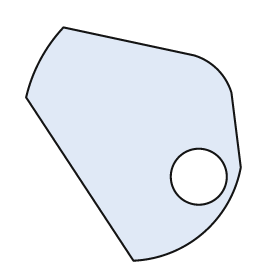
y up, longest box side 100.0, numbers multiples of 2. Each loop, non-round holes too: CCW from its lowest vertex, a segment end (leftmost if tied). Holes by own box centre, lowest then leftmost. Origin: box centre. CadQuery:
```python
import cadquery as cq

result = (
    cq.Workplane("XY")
    .moveTo(0.0, -50.0)
    .threePointArc((30.0, -38.0), (46.0, -10.0))
    .lineTo(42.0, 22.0)
    .threePointArc((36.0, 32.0), (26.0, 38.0))
    .lineTo(-30.0, 50.0)
    .threePointArc((-40.0, 36.0), (-46.0, 20.0))
    .close()
    .moveTo(28.0, -14.0)
    .circle(12.0)
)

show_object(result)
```